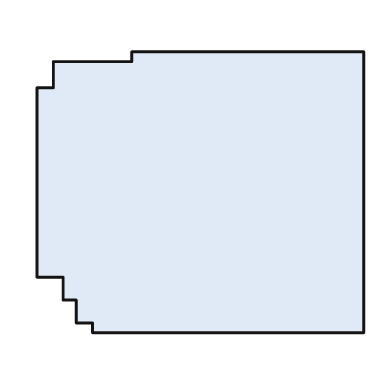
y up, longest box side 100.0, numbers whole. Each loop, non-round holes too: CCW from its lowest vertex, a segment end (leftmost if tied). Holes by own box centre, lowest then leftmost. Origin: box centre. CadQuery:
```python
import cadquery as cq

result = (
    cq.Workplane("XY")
    .moveTo(-33.0, -43.0)
    .lineTo(50.0, -43.0)
    .lineTo(50.0, 43.0)
    .lineTo(-21.0, 43.0)
    .lineTo(-21.0, 40.0)
    .lineTo(-45.0, 40.0)
    .lineTo(-45.0, 32.0)
    .lineTo(-50.0, 32.0)
    .lineTo(-50.0, -26.0)
    .lineTo(-42.0, -26.0)
    .lineTo(-42.0, -33.0)
    .lineTo(-38.0, -33.0)
    .lineTo(-38.0, -40.0)
    .lineTo(-33.0, -40.0)
    .close()
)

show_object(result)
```